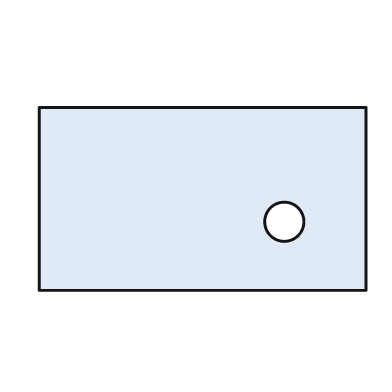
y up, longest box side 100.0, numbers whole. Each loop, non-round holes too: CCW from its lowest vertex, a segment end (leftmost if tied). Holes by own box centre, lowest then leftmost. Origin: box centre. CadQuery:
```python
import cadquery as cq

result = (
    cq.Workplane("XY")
    .moveTo(-50.0, -28.0)
    .lineTo(50.0, -28.0)
    .lineTo(50.0, 28.0)
    .lineTo(-50.0, 28.0)
    .close()
    .moveTo(25.0, -7.0)
    .circle(6.0)
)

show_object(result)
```